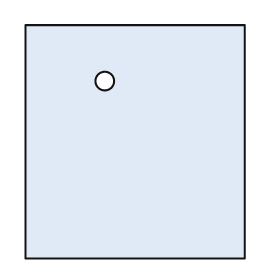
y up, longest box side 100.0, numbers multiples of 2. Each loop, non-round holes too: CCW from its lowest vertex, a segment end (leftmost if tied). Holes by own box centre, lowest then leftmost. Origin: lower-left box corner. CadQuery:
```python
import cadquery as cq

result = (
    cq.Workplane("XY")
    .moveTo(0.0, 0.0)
    .lineTo(94.0, 0.0)
    .lineTo(94.0, 100.0)
    .lineTo(0.0, 100.0)
    .close()
    .moveTo(34.0, 76.0)
    .circle(4.0)
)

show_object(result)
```